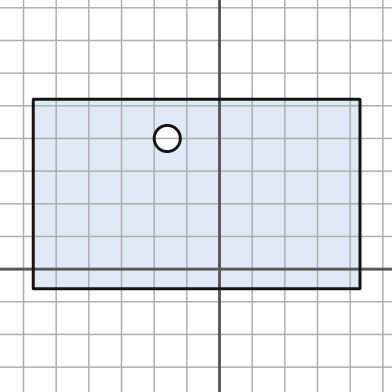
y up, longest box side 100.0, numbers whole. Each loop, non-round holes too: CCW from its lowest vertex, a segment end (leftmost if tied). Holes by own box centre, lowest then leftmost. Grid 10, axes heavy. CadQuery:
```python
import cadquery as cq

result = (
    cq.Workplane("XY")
    .moveTo(-57.0, -6.0)
    .lineTo(43.0, -6.0)
    .lineTo(43.0, 52.0)
    .lineTo(-57.0, 52.0)
    .close()
    .moveTo(-16.0, 40.0)
    .circle(4.0)
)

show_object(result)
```